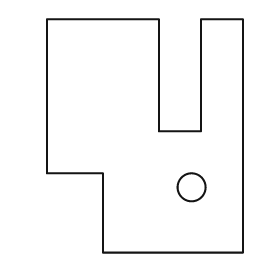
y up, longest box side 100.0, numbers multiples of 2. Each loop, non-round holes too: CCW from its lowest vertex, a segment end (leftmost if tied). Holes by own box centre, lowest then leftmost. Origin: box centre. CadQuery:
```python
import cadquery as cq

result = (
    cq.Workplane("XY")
    .moveTo(-18.0, -50.0)
    .lineTo(42.0, -50.0)
    .lineTo(42.0, 50.0)
    .lineTo(24.0, 50.0)
    .lineTo(24.0, 2.0)
    .lineTo(6.0, 2.0)
    .lineTo(6.0, 50.0)
    .lineTo(-42.0, 50.0)
    .lineTo(-42.0, -16.0)
    .lineTo(-18.0, -16.0)
    .close()
    .moveTo(20.0, -22.0)
    .circle(6.0)
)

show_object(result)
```